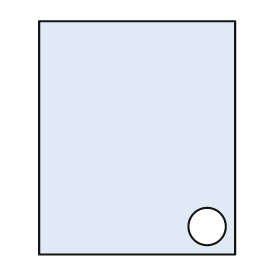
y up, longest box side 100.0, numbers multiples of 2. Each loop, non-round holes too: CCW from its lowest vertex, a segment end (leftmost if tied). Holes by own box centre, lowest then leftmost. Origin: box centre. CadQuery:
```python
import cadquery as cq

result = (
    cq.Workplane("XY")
    .moveTo(-42.0, -50.0)
    .lineTo(42.0, -50.0)
    .lineTo(42.0, 50.0)
    .lineTo(-42.0, 50.0)
    .close()
    .moveTo(30.0, -38.0)
    .circle(8.0)
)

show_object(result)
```